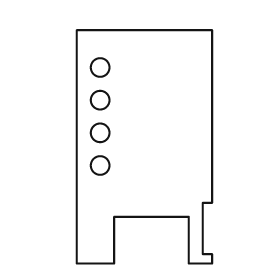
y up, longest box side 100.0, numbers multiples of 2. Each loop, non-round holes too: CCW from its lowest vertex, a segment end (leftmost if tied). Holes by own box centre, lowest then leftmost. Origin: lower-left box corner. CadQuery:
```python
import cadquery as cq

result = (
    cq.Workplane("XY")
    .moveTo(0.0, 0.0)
    .lineTo(16.0, 0.0)
    .lineTo(16.0, 20.0)
    .lineTo(48.0, 20.0)
    .lineTo(48.0, 0.0)
    .lineTo(58.0, 0.0)
    .lineTo(58.0, 4.0)
    .lineTo(54.0, 4.0)
    .lineTo(54.0, 26.0)
    .lineTo(58.0, 26.0)
    .lineTo(58.0, 100.0)
    .lineTo(0.0, 100.0)
    .close()
    .moveTo(10.0, 42.0)
    .circle(4.0)
    .moveTo(10.0, 56.0)
    .circle(4.0)
    .moveTo(10.0, 70.0)
    .circle(4.0)
    .moveTo(10.0, 84.0)
    .circle(4.0)
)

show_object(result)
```